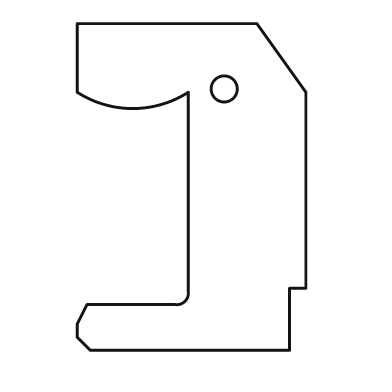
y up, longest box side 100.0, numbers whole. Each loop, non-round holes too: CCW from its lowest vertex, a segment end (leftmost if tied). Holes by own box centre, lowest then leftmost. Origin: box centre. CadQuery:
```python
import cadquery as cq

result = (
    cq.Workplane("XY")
    .moveTo(-31.0, -50.0)
    .lineTo(30.0, -50.0)
    .lineTo(30.0, -31.0)
    .lineTo(35.0, -31.0)
    .lineTo(35.0, 29.0)
    .lineTo(20.0, 50.0)
    .lineTo(-35.0, 50.0)
    .lineTo(-35.0, 29.0)
    .threePointArc((-18.0, 24.0), (-1.0, 29.0))
    .lineTo(-1.0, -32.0)
    .threePointArc((-2.0, -35.0), (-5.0, -36.0))
    .lineTo(-32.0, -36.0)
    .lineTo(-35.0, -42.0)
    .lineTo(-35.0, -46.0)
    .close()
    .moveTo(10.0, 30.0)
    .circle(4.0)
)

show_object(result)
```